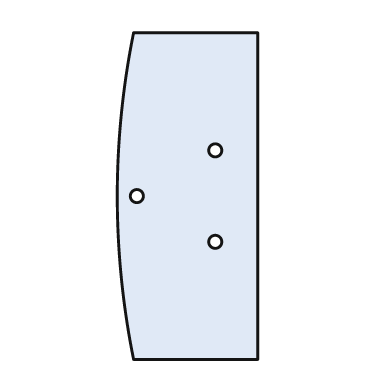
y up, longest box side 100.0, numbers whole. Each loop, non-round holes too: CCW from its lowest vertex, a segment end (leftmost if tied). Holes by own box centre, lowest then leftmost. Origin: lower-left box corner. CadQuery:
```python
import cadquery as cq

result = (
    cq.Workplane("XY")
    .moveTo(5.0, 0.0)
    .lineTo(43.0, 0.0)
    .lineTo(43.0, 100.0)
    .lineTo(5.0, 100.0)
    .threePointArc((0.0, 50.0), (5.0, 0.0))
    .close()
    .moveTo(30.0, 36.0)
    .circle(2.0)
    .moveTo(6.0, 50.0)
    .circle(2.0)
    .moveTo(30.0, 64.0)
    .circle(2.0)
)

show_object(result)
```